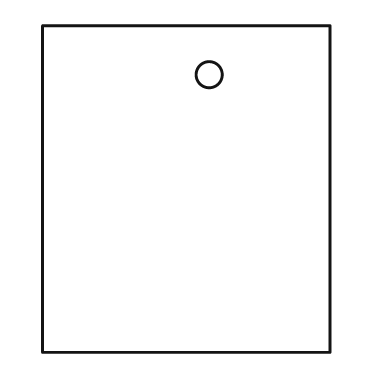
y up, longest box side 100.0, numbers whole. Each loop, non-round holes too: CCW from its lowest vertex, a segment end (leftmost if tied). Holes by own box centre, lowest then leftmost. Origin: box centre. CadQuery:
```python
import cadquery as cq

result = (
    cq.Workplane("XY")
    .moveTo(-44.0, -50.0)
    .lineTo(44.0, -50.0)
    .lineTo(44.0, 50.0)
    .lineTo(-44.0, 50.0)
    .close()
    .moveTo(7.0, 35.0)
    .circle(4.0)
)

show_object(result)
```